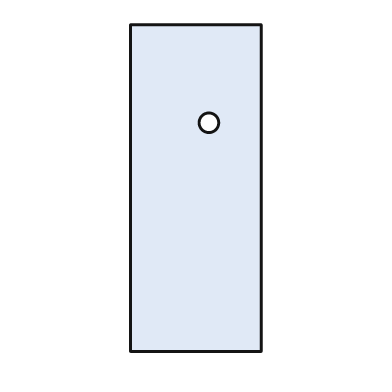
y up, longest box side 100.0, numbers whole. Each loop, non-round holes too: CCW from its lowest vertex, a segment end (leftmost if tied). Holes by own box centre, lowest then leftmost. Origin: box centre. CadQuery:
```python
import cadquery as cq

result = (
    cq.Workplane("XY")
    .moveTo(-20.0, -50.0)
    .lineTo(20.0, -50.0)
    .lineTo(20.0, 50.0)
    .lineTo(-20.0, 50.0)
    .close()
    .moveTo(4.0, 20.0)
    .circle(3.0)
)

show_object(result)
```